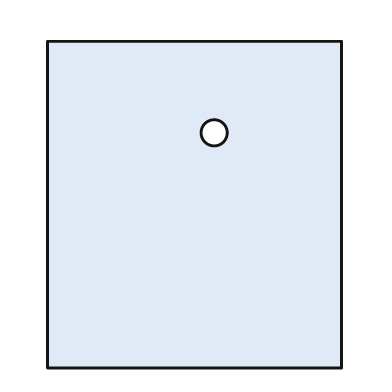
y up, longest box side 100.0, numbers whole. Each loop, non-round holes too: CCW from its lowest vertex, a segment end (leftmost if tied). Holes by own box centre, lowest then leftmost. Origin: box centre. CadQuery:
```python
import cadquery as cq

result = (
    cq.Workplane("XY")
    .moveTo(-45.0, -50.0)
    .lineTo(45.0, -50.0)
    .lineTo(45.0, 50.0)
    .lineTo(-45.0, 50.0)
    .close()
    .moveTo(6.0, 22.0)
    .circle(4.0)
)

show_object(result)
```